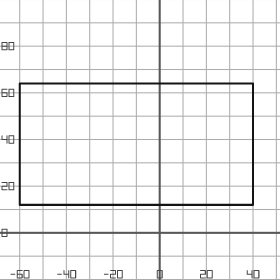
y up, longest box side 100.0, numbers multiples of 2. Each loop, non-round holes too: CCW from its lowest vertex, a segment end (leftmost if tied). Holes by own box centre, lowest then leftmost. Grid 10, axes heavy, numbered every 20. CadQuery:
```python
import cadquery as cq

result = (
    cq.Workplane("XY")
    .moveTo(-60.0, 12.0)
    .lineTo(40.0, 12.0)
    .lineTo(40.0, 64.0)
    .lineTo(-60.0, 64.0)
    .close()
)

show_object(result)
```